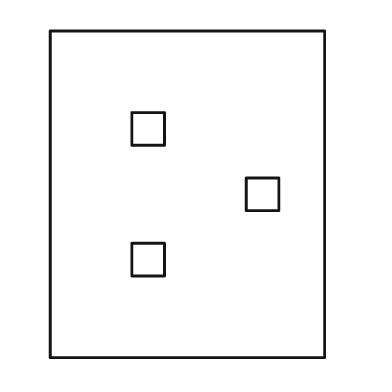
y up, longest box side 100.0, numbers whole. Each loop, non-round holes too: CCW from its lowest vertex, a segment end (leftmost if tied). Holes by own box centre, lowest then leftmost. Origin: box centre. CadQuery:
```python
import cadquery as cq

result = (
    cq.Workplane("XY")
    .moveTo(-42.0, -50.0)
    .lineTo(42.0, -50.0)
    .lineTo(42.0, 50.0)
    .lineTo(-42.0, 50.0)
    .close()
    .moveTo(-17.0, -25.0)
    .lineTo(-7.0, -25.0)
    .lineTo(-7.0, -15.0)
    .lineTo(-17.0, -15.0)
    .close()
    .moveTo(18.0, -5.0)
    .lineTo(28.0, -5.0)
    .lineTo(28.0, 5.0)
    .lineTo(18.0, 5.0)
    .close()
    .moveTo(-17.0, 15.0)
    .lineTo(-7.0, 15.0)
    .lineTo(-7.0, 25.0)
    .lineTo(-17.0, 25.0)
    .close()
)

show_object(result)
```